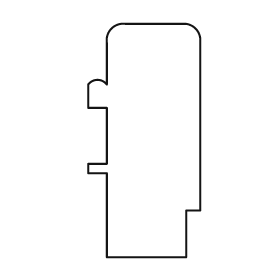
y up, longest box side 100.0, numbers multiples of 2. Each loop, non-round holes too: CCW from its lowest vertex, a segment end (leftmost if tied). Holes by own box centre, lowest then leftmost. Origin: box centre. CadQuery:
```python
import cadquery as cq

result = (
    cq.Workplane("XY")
    .moveTo(-16.0, -50.0)
    .lineTo(18.0, -50.0)
    .lineTo(18.0, -30.0)
    .lineTo(24.0, -30.0)
    .lineTo(24.0, 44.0)
    .threePointArc((22.0, 48.0), (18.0, 50.0))
    .lineTo(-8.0, 50.0)
    .threePointArc((-14.0, 48.0), (-16.0, 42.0))
    .lineTo(-16.0, 24.0)
    .threePointArc((-20.0, 26.0), (-24.0, 24.0))
    .lineTo(-24.0, 14.0)
    .lineTo(-16.0, 14.0)
    .lineTo(-16.0, -10.0)
    .lineTo(-24.0, -10.0)
    .lineTo(-24.0, -14.0)
    .lineTo(-16.0, -14.0)
    .close()
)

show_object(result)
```